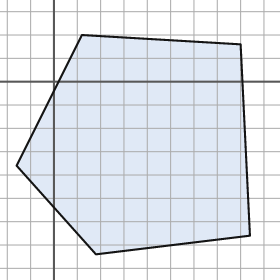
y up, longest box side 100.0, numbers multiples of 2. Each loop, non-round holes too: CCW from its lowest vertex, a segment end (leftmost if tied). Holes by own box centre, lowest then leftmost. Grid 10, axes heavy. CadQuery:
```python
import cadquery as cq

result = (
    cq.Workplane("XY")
    .moveTo(18.0, -74.0)
    .lineTo(84.0, -66.0)
    .lineTo(80.0, 16.0)
    .lineTo(12.0, 20.0)
    .lineTo(-16.0, -36.0)
    .close()
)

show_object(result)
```